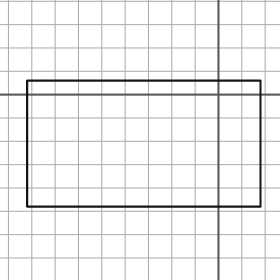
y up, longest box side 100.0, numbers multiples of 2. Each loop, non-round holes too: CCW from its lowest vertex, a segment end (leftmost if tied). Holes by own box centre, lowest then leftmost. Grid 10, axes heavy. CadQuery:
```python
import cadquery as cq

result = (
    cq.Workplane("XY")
    .moveTo(-82.0, -48.0)
    .lineTo(18.0, -48.0)
    .lineTo(18.0, 6.0)
    .lineTo(-82.0, 6.0)
    .close()
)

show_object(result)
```